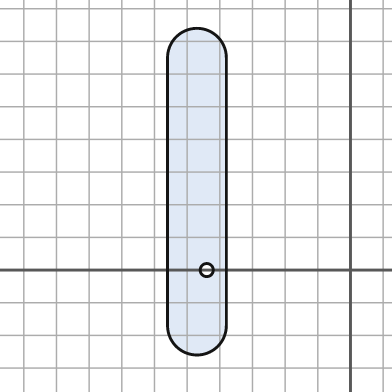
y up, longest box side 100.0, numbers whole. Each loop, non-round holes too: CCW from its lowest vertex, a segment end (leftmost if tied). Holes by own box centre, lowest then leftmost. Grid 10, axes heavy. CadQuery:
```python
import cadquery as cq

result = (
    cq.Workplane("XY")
    .moveTo(-56.0, -17.0)
    .threePointArc((-47.0, -26.0), (-38.0, -17.0))
    .lineTo(-38.0, 65.0)
    .threePointArc((-47.0, 74.0), (-56.0, 65.0))
    .close()
    .moveTo(-44.0, 0.0)
    .circle(2.0)
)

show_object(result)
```